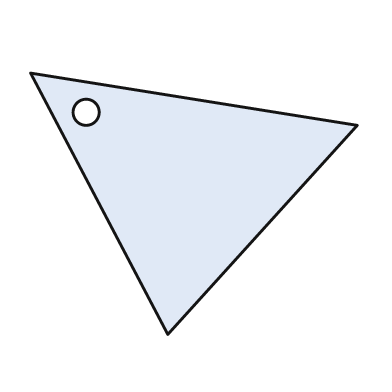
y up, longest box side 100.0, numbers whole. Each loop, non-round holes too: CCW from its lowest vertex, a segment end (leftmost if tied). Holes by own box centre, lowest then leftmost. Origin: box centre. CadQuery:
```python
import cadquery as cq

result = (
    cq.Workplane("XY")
    .moveTo(-8.0, -40.0)
    .lineTo(50.0, 24.0)
    .lineTo(-50.0, 40.0)
    .close()
    .moveTo(-33.0, 28.0)
    .circle(4.0)
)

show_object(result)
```